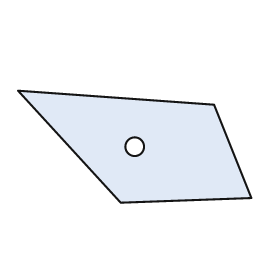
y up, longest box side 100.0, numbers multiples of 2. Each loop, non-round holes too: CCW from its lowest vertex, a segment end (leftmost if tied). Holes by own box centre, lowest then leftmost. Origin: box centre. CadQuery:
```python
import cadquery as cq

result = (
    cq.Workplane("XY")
    .moveTo(-6.0, -24.0)
    .lineTo(50.0, -22.0)
    .lineTo(34.0, 18.0)
    .lineTo(-50.0, 24.0)
    .close()
    .moveTo(0.0, 0.0)
    .circle(4.0)
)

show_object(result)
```